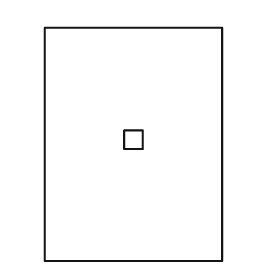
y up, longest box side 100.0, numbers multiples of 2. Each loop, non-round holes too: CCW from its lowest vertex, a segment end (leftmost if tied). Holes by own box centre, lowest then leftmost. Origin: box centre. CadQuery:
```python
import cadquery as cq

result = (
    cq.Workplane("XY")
    .moveTo(-38.0, -50.0)
    .lineTo(38.0, -50.0)
    .lineTo(38.0, 50.0)
    .lineTo(-38.0, 50.0)
    .close()
    .moveTo(-4.0, -2.0)
    .lineTo(4.0, -2.0)
    .lineTo(4.0, 6.0)
    .lineTo(-4.0, 6.0)
    .close()
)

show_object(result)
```